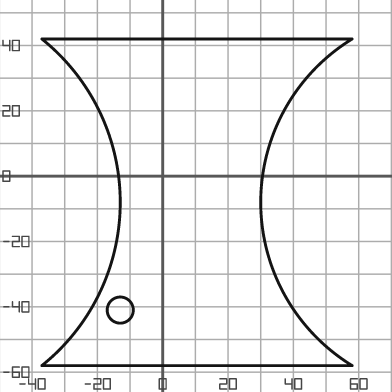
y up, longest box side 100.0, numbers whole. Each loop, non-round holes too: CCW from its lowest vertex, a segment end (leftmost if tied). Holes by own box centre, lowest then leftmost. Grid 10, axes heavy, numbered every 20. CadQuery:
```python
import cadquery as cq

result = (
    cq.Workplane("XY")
    .moveTo(-37.0, -58.0)
    .lineTo(58.0, -58.0)
    .threePointArc((30.0, -8.0), (58.0, 42.0))
    .lineTo(-37.0, 42.0)
    .threePointArc((-13.0, -8.0), (-37.0, -58.0))
    .close()
    .moveTo(-13.0, -41.0)
    .circle(4.0)
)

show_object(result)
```